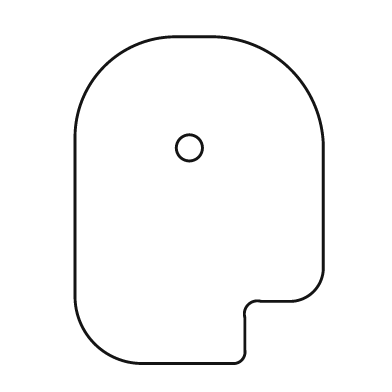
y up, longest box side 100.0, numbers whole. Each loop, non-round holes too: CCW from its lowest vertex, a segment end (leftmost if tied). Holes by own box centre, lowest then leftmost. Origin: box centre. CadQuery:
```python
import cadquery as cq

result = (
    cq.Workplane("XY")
    .moveTo(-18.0, -50.0)
    .lineTo(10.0, -50.0)
    .threePointArc((13.0, -49.0), (14.0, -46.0))
    .lineTo(14.0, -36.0)
    .threePointArc((15.0, -32.0), (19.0, -31.0))
    .lineTo(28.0, -31.0)
    .threePointArc((35.0, -28.0), (38.0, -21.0))
    .lineTo(38.0, 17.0)
    .threePointArc((28.0, 40.0), (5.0, 50.0))
    .lineTo(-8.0, 50.0)
    .threePointArc((-29.0, 41.0), (-38.0, 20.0))
    .lineTo(-38.0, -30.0)
    .threePointArc((-32.0, -44.0), (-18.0, -50.0))
    .close()
    .moveTo(-3.0, 16.0)
    .circle(4.0)
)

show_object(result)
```